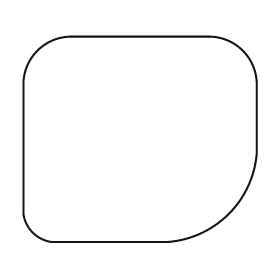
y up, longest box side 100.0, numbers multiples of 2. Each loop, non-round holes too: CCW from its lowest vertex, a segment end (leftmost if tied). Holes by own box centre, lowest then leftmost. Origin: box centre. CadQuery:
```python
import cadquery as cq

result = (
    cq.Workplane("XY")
    .moveTo(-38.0, -44.0)
    .lineTo(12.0, -44.0)
    .threePointArc((38.0, -32.0), (50.0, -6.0))
    .lineTo(50.0, 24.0)
    .threePointArc((44.0, 38.0), (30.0, 44.0))
    .lineTo(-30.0, 44.0)
    .threePointArc((-44.0, 38.0), (-50.0, 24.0))
    .lineTo(-50.0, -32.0)
    .threePointArc((-46.0, -40.0), (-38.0, -44.0))
    .close()
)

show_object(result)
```